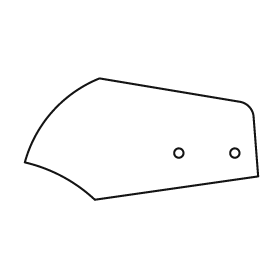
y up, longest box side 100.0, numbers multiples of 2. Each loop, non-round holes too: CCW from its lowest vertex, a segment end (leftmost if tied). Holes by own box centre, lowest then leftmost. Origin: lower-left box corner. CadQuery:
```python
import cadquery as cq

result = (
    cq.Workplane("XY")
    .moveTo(30.0, 0.0)
    .lineTo(100.0, 10.0)
    .lineTo(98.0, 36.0)
    .threePointArc((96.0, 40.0), (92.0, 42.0))
    .lineTo(32.0, 52.0)
    .threePointArc((12.0, 38.0), (0.0, 16.0))
    .threePointArc((16.0, 10.0), (30.0, 0.0))
    .close()
    .moveTo(66.0, 20.0)
    .circle(2.0)
    .moveTo(90.0, 20.0)
    .circle(2.0)
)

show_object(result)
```